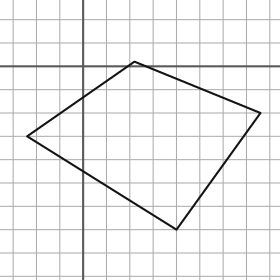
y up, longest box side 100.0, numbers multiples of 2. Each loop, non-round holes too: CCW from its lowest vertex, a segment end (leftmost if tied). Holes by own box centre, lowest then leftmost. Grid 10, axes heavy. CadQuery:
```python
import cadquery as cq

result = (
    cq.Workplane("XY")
    .moveTo(40.0, -70.0)
    .lineTo(76.0, -20.0)
    .lineTo(22.0, 2.0)
    .lineTo(-24.0, -30.0)
    .close()
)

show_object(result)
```